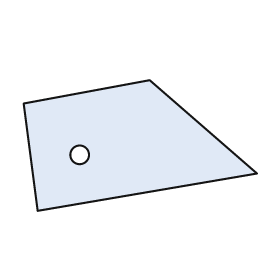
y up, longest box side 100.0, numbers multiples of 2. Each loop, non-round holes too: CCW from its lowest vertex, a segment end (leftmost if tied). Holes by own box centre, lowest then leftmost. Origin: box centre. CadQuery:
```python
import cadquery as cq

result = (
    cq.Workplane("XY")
    .moveTo(-44.0, -28.0)
    .lineTo(50.0, -12.0)
    .lineTo(4.0, 28.0)
    .lineTo(-50.0, 18.0)
    .close()
    .moveTo(-26.0, -4.0)
    .circle(4.0)
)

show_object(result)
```